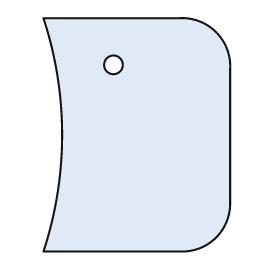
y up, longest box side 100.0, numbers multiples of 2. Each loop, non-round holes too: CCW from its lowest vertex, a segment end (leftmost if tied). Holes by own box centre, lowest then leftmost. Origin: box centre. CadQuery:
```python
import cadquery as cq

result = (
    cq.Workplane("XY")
    .moveTo(-40.0, -50.0)
    .lineTo(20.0, -50.0)
    .threePointArc((34.0, -44.0), (40.0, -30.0))
    .lineTo(40.0, 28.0)
    .threePointArc((34.0, 44.0), (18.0, 50.0))
    .lineTo(-40.0, 50.0)
    .threePointArc((-32.0, 0.0), (-40.0, -50.0))
    .close()
    .moveTo(-10.0, 30.0)
    .circle(4.0)
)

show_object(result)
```